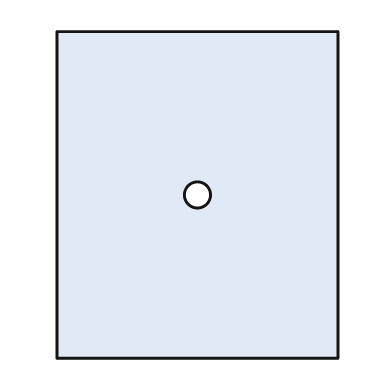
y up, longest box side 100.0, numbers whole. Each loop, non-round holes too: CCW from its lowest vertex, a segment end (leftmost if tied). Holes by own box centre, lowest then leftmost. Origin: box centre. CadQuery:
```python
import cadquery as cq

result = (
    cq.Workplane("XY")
    .moveTo(-43.0, -50.0)
    .lineTo(43.0, -50.0)
    .lineTo(43.0, 50.0)
    .lineTo(-43.0, 50.0)
    .close()
    .moveTo(0.0, 0.0)
    .circle(4.0)
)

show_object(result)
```